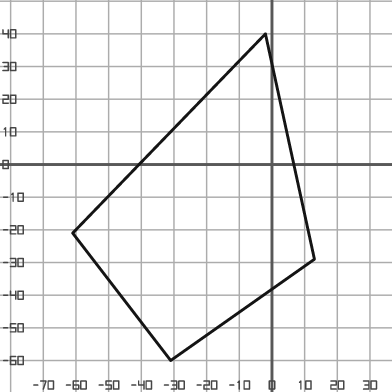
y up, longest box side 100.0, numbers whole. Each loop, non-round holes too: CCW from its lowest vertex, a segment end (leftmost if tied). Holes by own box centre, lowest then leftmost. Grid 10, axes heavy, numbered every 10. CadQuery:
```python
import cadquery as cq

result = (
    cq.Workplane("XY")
    .moveTo(-31.0, -60.0)
    .lineTo(13.0, -29.0)
    .lineTo(-2.0, 40.0)
    .lineTo(-61.0, -21.0)
    .close()
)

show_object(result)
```